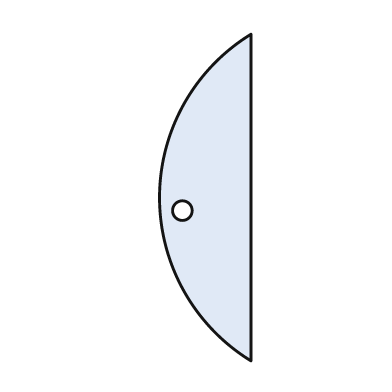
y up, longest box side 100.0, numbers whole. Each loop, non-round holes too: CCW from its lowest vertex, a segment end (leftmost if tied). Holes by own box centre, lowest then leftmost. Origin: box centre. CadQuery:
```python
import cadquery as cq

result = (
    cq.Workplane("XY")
    .moveTo(14.0, -50.0)
    .lineTo(14.0, 50.0)
    .threePointArc((-14.0, 0.0), (14.0, -50.0))
    .close()
    .moveTo(-7.0, -4.0)
    .circle(3.0)
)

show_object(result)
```